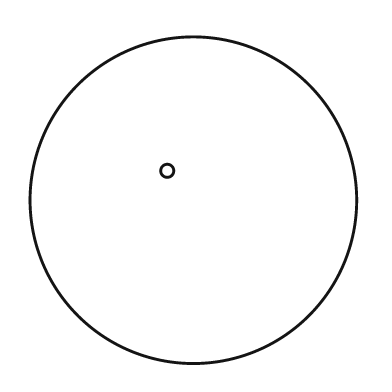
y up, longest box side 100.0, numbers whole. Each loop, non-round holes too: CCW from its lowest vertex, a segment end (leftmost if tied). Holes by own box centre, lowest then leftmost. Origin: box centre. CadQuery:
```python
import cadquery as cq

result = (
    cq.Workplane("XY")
    .moveTo(0.0, 0.0)
    .circle(50.0)
    .moveTo(-8.0, 9.0)
    .circle(2.0)
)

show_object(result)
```